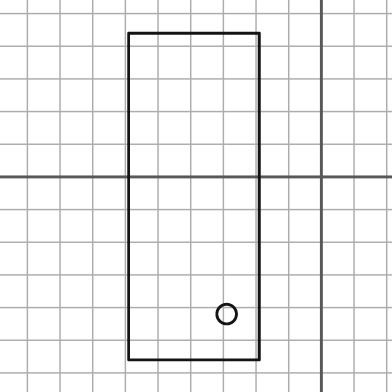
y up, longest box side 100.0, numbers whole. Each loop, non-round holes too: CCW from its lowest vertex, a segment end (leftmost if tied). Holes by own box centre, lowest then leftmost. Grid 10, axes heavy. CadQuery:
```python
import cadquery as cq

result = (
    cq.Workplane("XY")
    .moveTo(-59.0, -56.0)
    .lineTo(-19.0, -56.0)
    .lineTo(-19.0, 44.0)
    .lineTo(-59.0, 44.0)
    .close()
    .moveTo(-29.0, -42.0)
    .circle(3.0)
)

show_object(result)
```